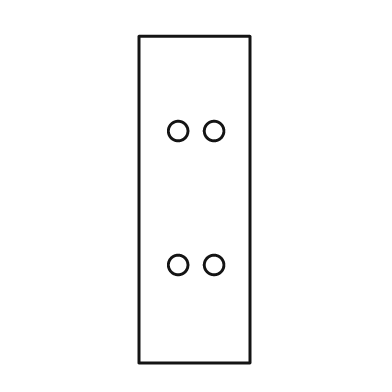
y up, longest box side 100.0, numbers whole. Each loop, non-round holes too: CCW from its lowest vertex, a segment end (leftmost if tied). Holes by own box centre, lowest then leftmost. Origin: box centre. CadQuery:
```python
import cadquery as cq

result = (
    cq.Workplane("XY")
    .moveTo(-17.0, -50.0)
    .lineTo(17.0, -50.0)
    .lineTo(17.0, 50.0)
    .lineTo(-17.0, 50.0)
    .close()
    .moveTo(-5.0, -20.0)
    .circle(3.0)
    .moveTo(6.0, -20.0)
    .circle(3.0)
    .moveTo(-5.0, 21.0)
    .circle(3.0)
    .moveTo(6.0, 21.0)
    .circle(3.0)
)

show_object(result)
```